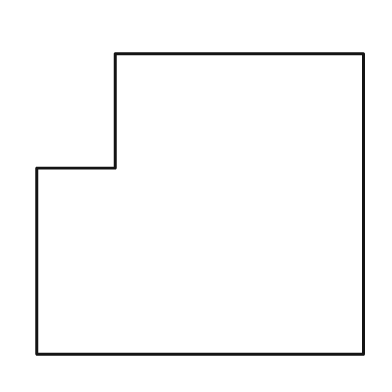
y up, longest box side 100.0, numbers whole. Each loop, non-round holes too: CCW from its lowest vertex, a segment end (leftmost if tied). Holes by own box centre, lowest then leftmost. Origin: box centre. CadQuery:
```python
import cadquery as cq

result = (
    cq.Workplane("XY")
    .moveTo(-50.0, -46.0)
    .lineTo(50.0, -46.0)
    .lineTo(50.0, 46.0)
    .lineTo(-26.0, 46.0)
    .lineTo(-26.0, 11.0)
    .lineTo(-50.0, 11.0)
    .close()
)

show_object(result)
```